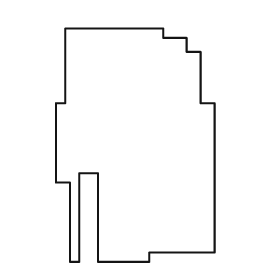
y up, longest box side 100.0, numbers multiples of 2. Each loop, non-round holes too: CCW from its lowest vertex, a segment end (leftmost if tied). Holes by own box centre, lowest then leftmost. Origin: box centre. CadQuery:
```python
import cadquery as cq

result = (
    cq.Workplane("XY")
    .moveTo(-28.0, -50.0)
    .lineTo(-24.0, -50.0)
    .lineTo(-24.0, -12.0)
    .lineTo(-16.0, -12.0)
    .lineTo(-16.0, -50.0)
    .lineTo(6.0, -50.0)
    .lineTo(6.0, -46.0)
    .lineTo(34.0, -46.0)
    .lineTo(34.0, 18.0)
    .lineTo(28.0, 18.0)
    .lineTo(28.0, 40.0)
    .lineTo(22.0, 40.0)
    .lineTo(22.0, 46.0)
    .lineTo(12.0, 46.0)
    .lineTo(12.0, 50.0)
    .lineTo(-30.0, 50.0)
    .lineTo(-30.0, 18.0)
    .lineTo(-34.0, 18.0)
    .lineTo(-34.0, -16.0)
    .lineTo(-28.0, -16.0)
    .close()
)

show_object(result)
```